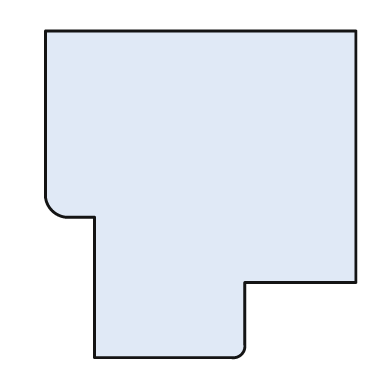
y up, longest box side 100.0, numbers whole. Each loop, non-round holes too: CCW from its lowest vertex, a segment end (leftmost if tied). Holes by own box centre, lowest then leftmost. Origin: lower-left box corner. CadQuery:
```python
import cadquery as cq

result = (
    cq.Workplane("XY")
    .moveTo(15.0, 0.0)
    .lineTo(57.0, 0.0)
    .threePointArc((60.0, 1.0), (61.0, 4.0))
    .lineTo(61.0, 23.0)
    .lineTo(95.0, 23.0)
    .lineTo(95.0, 100.0)
    .lineTo(0.0, 100.0)
    .lineTo(0.0, 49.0)
    .threePointArc((2.0, 45.0), (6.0, 43.0))
    .lineTo(15.0, 43.0)
    .close()
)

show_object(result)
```